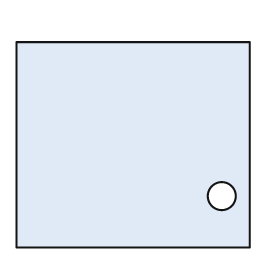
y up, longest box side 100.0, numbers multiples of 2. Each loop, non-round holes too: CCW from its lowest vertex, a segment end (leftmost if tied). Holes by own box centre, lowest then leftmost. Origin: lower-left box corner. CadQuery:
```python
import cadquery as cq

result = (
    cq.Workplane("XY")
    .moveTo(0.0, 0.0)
    .lineTo(100.0, 0.0)
    .lineTo(100.0, 88.0)
    .lineTo(0.0, 88.0)
    .close()
    .moveTo(88.0, 22.0)
    .circle(6.0)
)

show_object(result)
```